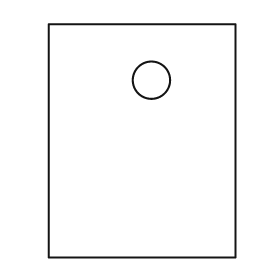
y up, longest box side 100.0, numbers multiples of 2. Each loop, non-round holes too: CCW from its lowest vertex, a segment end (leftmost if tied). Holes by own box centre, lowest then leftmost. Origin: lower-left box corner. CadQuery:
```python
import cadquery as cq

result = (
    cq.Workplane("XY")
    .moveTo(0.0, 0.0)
    .lineTo(80.0, 0.0)
    .lineTo(80.0, 100.0)
    .lineTo(0.0, 100.0)
    .close()
    .moveTo(44.0, 76.0)
    .circle(8.0)
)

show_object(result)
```